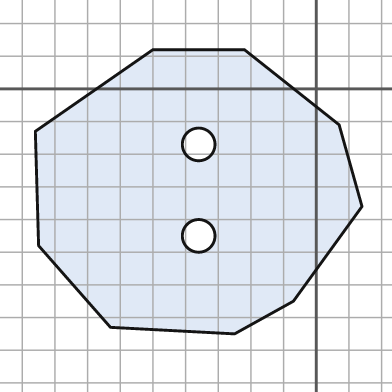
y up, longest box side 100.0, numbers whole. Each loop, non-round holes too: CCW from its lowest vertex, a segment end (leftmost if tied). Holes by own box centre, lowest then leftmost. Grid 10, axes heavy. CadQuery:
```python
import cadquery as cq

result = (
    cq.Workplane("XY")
    .moveTo(-25.0, -75.0)
    .lineTo(-7.0, -65.0)
    .lineTo(14.0, -36.0)
    .lineTo(7.0, -11.0)
    .lineTo(-22.0, 12.0)
    .lineTo(-50.0, 12.0)
    .lineTo(-86.0, -13.0)
    .lineTo(-85.0, -48.0)
    .lineTo(-63.0, -73.0)
    .close()
    .moveTo(-36.0, -45.0)
    .circle(5.0)
    .moveTo(-36.0, -17.0)
    .circle(5.0)
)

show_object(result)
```